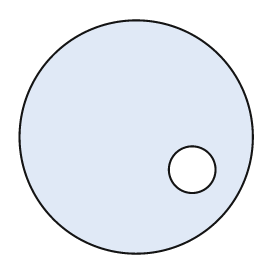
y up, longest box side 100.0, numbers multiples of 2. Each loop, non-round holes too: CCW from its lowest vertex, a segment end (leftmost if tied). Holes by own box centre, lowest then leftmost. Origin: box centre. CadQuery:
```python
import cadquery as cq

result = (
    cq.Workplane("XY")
    .moveTo(0.0, 0.0)
    .circle(50.0)
    .moveTo(24.0, -14.0)
    .circle(10.0)
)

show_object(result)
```